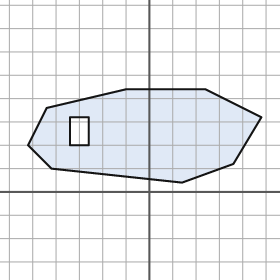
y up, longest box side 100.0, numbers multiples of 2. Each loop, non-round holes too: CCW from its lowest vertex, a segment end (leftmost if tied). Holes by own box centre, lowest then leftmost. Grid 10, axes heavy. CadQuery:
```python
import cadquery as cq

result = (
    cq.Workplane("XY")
    .moveTo(14.0, 4.0)
    .lineTo(36.0, 12.0)
    .lineTo(48.0, 32.0)
    .lineTo(24.0, 44.0)
    .lineTo(-10.0, 44.0)
    .lineTo(-44.0, 36.0)
    .lineTo(-52.0, 20.0)
    .lineTo(-42.0, 10.0)
    .close()
    .moveTo(-34.0, 20.0)
    .lineTo(-26.0, 20.0)
    .lineTo(-26.0, 32.0)
    .lineTo(-34.0, 32.0)
    .close()
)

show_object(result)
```